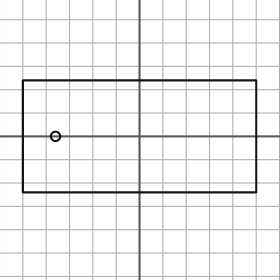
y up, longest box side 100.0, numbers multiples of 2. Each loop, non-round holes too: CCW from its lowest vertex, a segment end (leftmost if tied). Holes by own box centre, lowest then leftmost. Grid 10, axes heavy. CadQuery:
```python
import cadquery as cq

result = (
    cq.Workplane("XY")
    .moveTo(-50.0, -24.0)
    .lineTo(50.0, -24.0)
    .lineTo(50.0, 24.0)
    .lineTo(-50.0, 24.0)
    .close()
    .moveTo(-36.0, 0.0)
    .circle(2.0)
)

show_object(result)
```